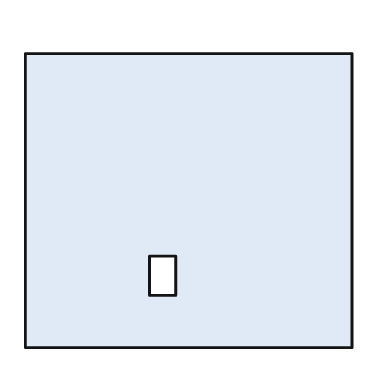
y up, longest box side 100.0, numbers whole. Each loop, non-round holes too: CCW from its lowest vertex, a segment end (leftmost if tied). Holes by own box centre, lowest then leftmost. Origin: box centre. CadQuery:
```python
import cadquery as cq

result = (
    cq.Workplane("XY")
    .moveTo(-50.0, -45.0)
    .lineTo(50.0, -45.0)
    .lineTo(50.0, 45.0)
    .lineTo(-50.0, 45.0)
    .close()
    .moveTo(-12.0, -29.0)
    .lineTo(-4.0, -29.0)
    .lineTo(-4.0, -17.0)
    .lineTo(-12.0, -17.0)
    .close()
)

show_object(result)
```